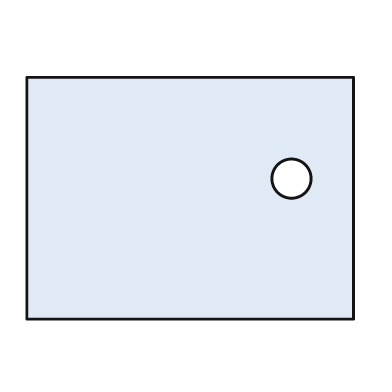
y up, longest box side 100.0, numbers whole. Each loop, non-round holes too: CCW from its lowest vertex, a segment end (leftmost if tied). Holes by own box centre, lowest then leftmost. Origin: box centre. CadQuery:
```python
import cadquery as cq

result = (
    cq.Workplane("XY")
    .moveTo(-50.0, -37.0)
    .lineTo(50.0, -37.0)
    .lineTo(50.0, 37.0)
    .lineTo(-50.0, 37.0)
    .close()
    .moveTo(31.0, 6.0)
    .circle(6.0)
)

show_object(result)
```